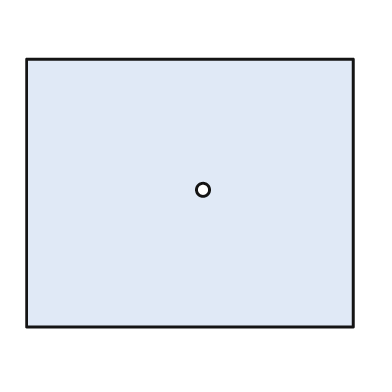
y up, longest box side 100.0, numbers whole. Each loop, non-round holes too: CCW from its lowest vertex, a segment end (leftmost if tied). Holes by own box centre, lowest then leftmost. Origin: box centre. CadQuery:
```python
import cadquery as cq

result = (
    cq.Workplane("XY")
    .moveTo(-50.0, -41.0)
    .lineTo(50.0, -41.0)
    .lineTo(50.0, 41.0)
    .lineTo(-50.0, 41.0)
    .close()
    .moveTo(4.0, 1.0)
    .circle(2.0)
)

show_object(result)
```